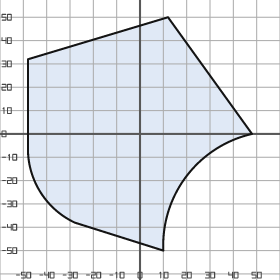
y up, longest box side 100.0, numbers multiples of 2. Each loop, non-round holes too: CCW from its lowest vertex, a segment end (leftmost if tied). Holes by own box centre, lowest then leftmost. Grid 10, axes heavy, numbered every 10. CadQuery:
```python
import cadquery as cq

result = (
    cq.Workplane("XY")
    .moveTo(10.0, -50.0)
    .threePointArc((20.0, -18.0), (48.0, 0.0))
    .lineTo(12.0, 50.0)
    .lineTo(-48.0, 32.0)
    .lineTo(-48.0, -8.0)
    .threePointArc((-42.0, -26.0), (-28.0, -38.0))
    .close()
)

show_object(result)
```